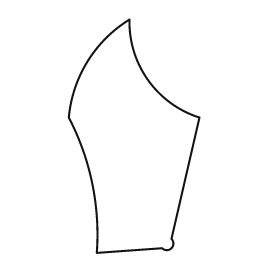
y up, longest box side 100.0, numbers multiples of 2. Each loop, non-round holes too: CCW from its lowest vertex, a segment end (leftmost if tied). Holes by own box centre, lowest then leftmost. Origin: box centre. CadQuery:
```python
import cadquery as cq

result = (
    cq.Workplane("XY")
    .moveTo(-16.0, -50.0)
    .lineTo(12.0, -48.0)
    .threePointArc((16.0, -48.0), (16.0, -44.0))
    .lineTo(28.0, 8.0)
    .threePointArc((6.0, 24.0), (-2.0, 50.0))
    .threePointArc((-20.0, 32.0), (-28.0, 8.0))
    .threePointArc((-18.0, -20.0), (-16.0, -50.0))
    .close()
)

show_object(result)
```